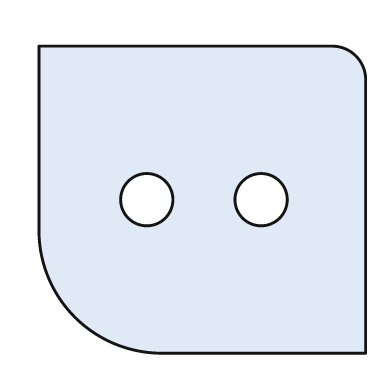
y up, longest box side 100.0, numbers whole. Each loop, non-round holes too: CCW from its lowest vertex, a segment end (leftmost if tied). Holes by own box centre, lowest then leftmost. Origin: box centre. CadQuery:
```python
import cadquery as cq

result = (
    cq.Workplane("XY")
    .moveTo(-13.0, -47.0)
    .lineTo(50.0, -47.0)
    .lineTo(50.0, 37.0)
    .threePointArc((47.0, 44.0), (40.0, 47.0))
    .lineTo(-50.0, 47.0)
    .lineTo(-50.0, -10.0)
    .threePointArc((-39.0, -36.0), (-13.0, -47.0))
    .close()
    .moveTo(-17.0, 0.0)
    .circle(8.0)
    .moveTo(18.0, 0.0)
    .circle(8.0)
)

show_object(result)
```